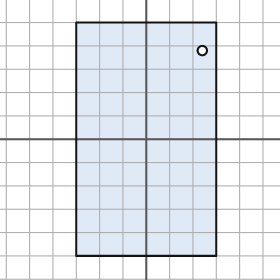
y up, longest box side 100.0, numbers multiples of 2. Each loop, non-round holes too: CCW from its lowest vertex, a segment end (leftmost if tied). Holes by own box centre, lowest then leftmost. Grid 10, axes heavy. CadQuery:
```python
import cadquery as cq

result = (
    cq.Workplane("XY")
    .moveTo(-30.0, -50.0)
    .lineTo(30.0, -50.0)
    .lineTo(30.0, 50.0)
    .lineTo(-30.0, 50.0)
    .close()
    .moveTo(24.0, 38.0)
    .circle(2.0)
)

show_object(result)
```